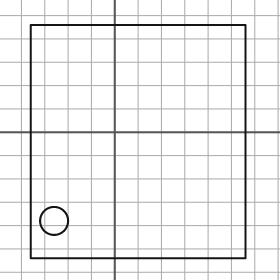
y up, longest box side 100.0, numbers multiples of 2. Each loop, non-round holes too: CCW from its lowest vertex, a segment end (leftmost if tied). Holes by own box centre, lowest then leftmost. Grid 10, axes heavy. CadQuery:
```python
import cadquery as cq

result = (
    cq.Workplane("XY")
    .moveTo(-36.0, -54.0)
    .lineTo(56.0, -54.0)
    .lineTo(56.0, 46.0)
    .lineTo(-36.0, 46.0)
    .close()
    .moveTo(-26.0, -38.0)
    .circle(6.0)
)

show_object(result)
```